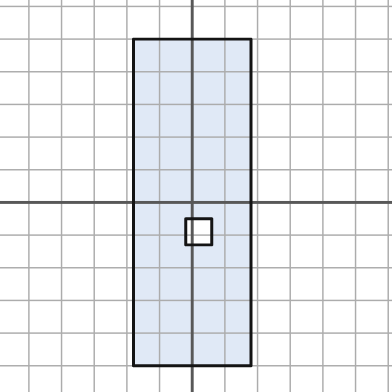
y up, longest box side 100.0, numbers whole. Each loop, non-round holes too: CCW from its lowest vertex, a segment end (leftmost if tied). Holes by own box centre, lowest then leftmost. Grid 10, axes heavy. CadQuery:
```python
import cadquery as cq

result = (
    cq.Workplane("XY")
    .moveTo(-18.0, -50.0)
    .lineTo(18.0, -50.0)
    .lineTo(18.0, 50.0)
    .lineTo(-18.0, 50.0)
    .close()
    .moveTo(-2.0, -13.0)
    .lineTo(6.0, -13.0)
    .lineTo(6.0, -5.0)
    .lineTo(-2.0, -5.0)
    .close()
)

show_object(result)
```